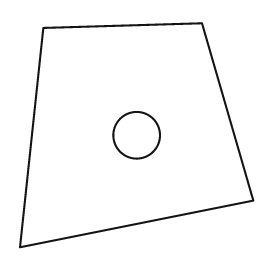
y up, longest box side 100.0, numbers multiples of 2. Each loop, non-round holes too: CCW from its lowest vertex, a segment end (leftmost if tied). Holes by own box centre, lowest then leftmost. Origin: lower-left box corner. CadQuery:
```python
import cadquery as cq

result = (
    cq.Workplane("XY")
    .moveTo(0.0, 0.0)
    .lineTo(100.0, 20.0)
    .lineTo(78.0, 96.0)
    .lineTo(10.0, 94.0)
    .close()
    .moveTo(50.0, 48.0)
    .circle(10.0)
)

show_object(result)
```